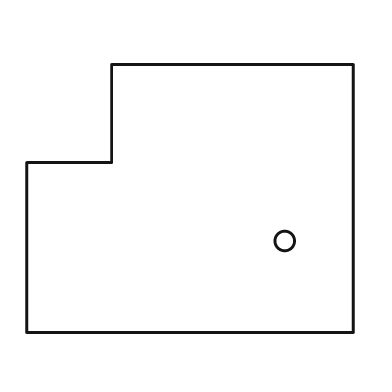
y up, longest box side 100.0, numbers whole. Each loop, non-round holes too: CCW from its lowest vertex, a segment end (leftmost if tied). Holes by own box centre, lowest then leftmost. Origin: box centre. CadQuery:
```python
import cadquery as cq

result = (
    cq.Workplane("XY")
    .moveTo(-50.0, -41.0)
    .lineTo(50.0, -41.0)
    .lineTo(50.0, 41.0)
    .lineTo(-24.0, 41.0)
    .lineTo(-24.0, 11.0)
    .lineTo(-50.0, 11.0)
    .close()
    .moveTo(29.0, -13.0)
    .circle(3.0)
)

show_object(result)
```